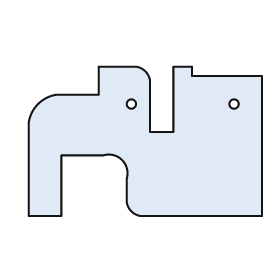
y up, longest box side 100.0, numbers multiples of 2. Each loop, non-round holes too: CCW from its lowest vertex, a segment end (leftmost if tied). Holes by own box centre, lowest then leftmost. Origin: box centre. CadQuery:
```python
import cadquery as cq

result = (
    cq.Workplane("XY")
    .moveTo(-50.0, -32.0)
    .lineTo(-36.0, -32.0)
    .lineTo(-36.0, -6.0)
    .lineTo(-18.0, -6.0)
    .threePointArc((-10.0, -8.0), (-8.0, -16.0))
    .lineTo(-8.0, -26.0)
    .threePointArc((-6.0, -30.0), (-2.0, -32.0))
    .lineTo(50.0, -32.0)
    .lineTo(50.0, 28.0)
    .lineTo(20.0, 28.0)
    .lineTo(20.0, 32.0)
    .lineTo(12.0, 32.0)
    .lineTo(12.0, 4.0)
    .lineTo(2.0, 4.0)
    .lineTo(2.0, 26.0)
    .threePointArc((0.0, 30.0), (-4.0, 32.0))
    .lineTo(-20.0, 32.0)
    .lineTo(-20.0, 20.0)
    .lineTo(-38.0, 20.0)
    .threePointArc((-46.0, 16.0), (-50.0, 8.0))
    .close()
    .moveTo(-6.0, 16.0)
    .circle(2.0)
    .moveTo(38.0, 16.0)
    .circle(2.0)
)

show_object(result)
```